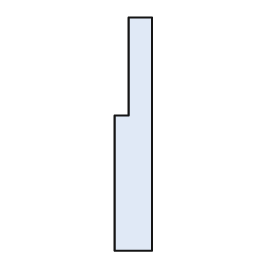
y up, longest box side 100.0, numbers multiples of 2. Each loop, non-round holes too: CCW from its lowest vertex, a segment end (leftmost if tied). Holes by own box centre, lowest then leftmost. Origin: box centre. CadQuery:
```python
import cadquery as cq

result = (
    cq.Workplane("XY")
    .moveTo(-8.0, -50.0)
    .lineTo(8.0, -50.0)
    .lineTo(8.0, 50.0)
    .lineTo(-2.0, 50.0)
    .lineTo(-2.0, 8.0)
    .lineTo(-8.0, 8.0)
    .close()
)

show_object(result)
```